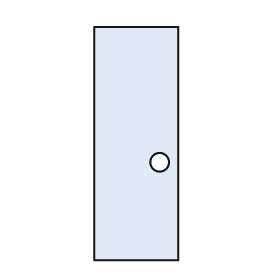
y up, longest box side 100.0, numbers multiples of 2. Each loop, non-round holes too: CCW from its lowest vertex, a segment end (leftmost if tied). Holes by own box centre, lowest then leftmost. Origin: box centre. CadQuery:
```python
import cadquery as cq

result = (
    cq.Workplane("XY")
    .moveTo(-18.0, -50.0)
    .lineTo(18.0, -50.0)
    .lineTo(18.0, 50.0)
    .lineTo(-18.0, 50.0)
    .close()
    .moveTo(10.0, -8.0)
    .circle(4.0)
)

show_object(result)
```